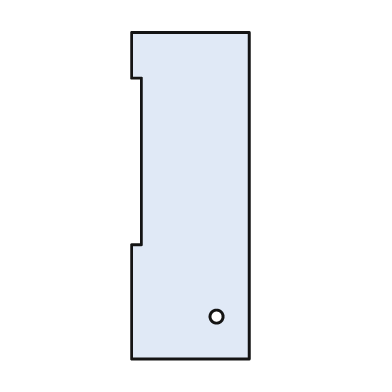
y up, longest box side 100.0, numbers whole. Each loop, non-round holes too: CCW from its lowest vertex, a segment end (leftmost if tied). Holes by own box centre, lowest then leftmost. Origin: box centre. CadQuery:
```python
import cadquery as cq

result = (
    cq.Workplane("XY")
    .moveTo(-18.0, -50.0)
    .lineTo(18.0, -50.0)
    .lineTo(18.0, 50.0)
    .lineTo(-18.0, 50.0)
    .lineTo(-18.0, 36.0)
    .lineTo(-15.0, 36.0)
    .lineTo(-15.0, -15.0)
    .lineTo(-18.0, -15.0)
    .close()
    .moveTo(8.0, -37.0)
    .circle(2.0)
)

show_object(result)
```